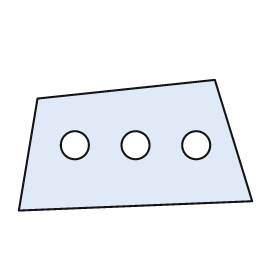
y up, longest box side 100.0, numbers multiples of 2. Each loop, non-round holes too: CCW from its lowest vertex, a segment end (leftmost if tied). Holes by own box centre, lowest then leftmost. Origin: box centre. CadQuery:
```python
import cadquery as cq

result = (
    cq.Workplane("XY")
    .moveTo(-50.0, -28.0)
    .lineTo(50.0, -24.0)
    .lineTo(34.0, 28.0)
    .lineTo(-42.0, 20.0)
    .close()
    .moveTo(-26.0, 0.0)
    .circle(6.0)
    .moveTo(0.0, 0.0)
    .circle(6.0)
    .moveTo(26.0, 0.0)
    .circle(6.0)
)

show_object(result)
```